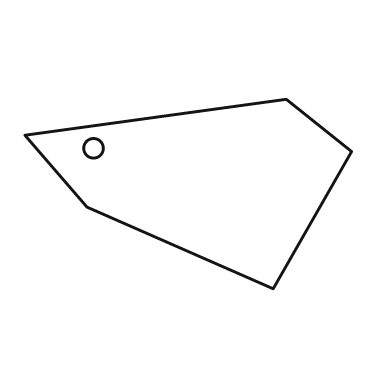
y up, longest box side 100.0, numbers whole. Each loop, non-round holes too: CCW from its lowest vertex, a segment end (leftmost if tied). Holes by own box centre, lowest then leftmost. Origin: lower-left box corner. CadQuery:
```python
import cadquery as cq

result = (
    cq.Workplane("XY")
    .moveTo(76.0, 0.0)
    .lineTo(100.0, 42.0)
    .lineTo(80.0, 58.0)
    .lineTo(0.0, 47.0)
    .lineTo(19.0, 25.0)
    .close()
    .moveTo(21.0, 43.0)
    .circle(3.0)
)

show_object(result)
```